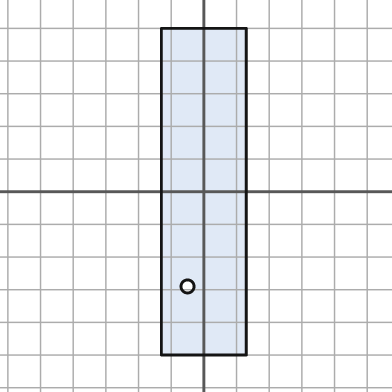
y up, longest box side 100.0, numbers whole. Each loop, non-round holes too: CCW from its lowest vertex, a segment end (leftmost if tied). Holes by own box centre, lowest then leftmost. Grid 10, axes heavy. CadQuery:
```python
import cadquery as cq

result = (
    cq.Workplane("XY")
    .moveTo(-13.0, -50.0)
    .lineTo(13.0, -50.0)
    .lineTo(13.0, 50.0)
    .lineTo(-13.0, 50.0)
    .close()
    .moveTo(-5.0, -29.0)
    .circle(2.0)
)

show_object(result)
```